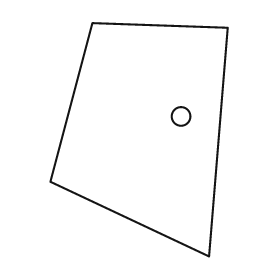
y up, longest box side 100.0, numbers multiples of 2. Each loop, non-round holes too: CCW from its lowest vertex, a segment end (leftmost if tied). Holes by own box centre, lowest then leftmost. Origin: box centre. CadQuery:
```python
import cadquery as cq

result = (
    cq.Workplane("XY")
    .moveTo(30.0, -50.0)
    .lineTo(38.0, 48.0)
    .lineTo(-20.0, 50.0)
    .lineTo(-38.0, -18.0)
    .close()
    .moveTo(18.0, 10.0)
    .circle(4.0)
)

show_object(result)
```